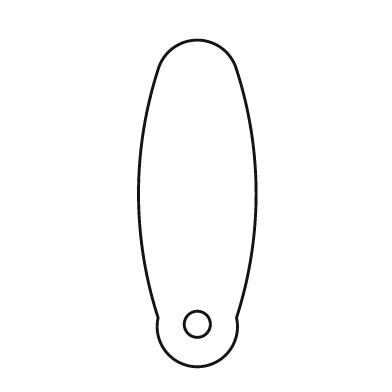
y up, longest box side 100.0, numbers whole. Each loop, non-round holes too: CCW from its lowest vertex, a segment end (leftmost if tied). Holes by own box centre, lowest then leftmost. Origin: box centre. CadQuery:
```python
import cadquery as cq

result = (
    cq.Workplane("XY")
    .moveTo(-12.0, -35.0)
    .threePointArc((0.0, -50.0), (12.0, -35.0))
    .threePointArc((18.0, 3.0), (12.0, 41.0))
    .threePointArc((0.0, 50.0), (-12.0, 41.0))
    .threePointArc((-18.0, 3.0), (-12.0, -35.0))
    .close()
    .moveTo(0.0, -37.0)
    .circle(4.0)
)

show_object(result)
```